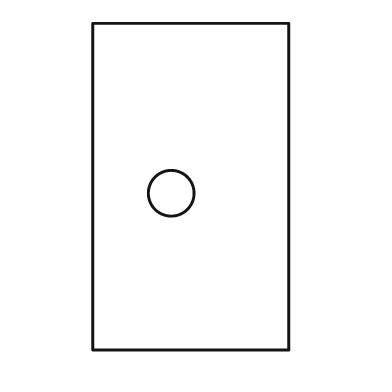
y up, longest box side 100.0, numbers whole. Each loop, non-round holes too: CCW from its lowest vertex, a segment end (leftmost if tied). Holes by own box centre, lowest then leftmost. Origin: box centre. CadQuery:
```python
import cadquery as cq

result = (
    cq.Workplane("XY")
    .moveTo(-30.0, -50.0)
    .lineTo(30.0, -50.0)
    .lineTo(30.0, 50.0)
    .lineTo(-30.0, 50.0)
    .close()
    .moveTo(-6.0, -2.0)
    .circle(7.0)
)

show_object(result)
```